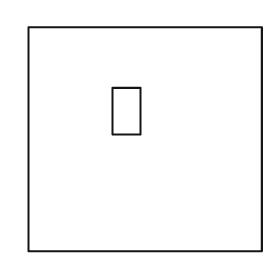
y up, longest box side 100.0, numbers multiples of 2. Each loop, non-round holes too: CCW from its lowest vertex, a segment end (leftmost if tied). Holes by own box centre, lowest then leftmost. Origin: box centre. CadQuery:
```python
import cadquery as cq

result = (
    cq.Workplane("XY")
    .moveTo(-50.0, -48.0)
    .lineTo(50.0, -48.0)
    .lineTo(50.0, 48.0)
    .lineTo(-50.0, 48.0)
    .close()
    .moveTo(-14.0, 2.0)
    .lineTo(-2.0, 2.0)
    .lineTo(-2.0, 22.0)
    .lineTo(-14.0, 22.0)
    .close()
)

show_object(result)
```